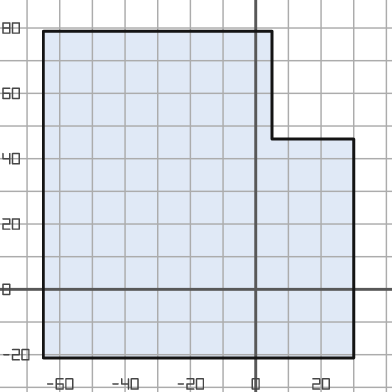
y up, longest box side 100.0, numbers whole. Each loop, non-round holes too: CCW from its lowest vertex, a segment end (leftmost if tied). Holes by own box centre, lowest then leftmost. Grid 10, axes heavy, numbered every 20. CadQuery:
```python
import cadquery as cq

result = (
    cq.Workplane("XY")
    .moveTo(-65.0, -21.0)
    .lineTo(30.0, -21.0)
    .lineTo(30.0, 46.0)
    .lineTo(5.0, 46.0)
    .lineTo(5.0, 79.0)
    .lineTo(-65.0, 79.0)
    .close()
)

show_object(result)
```